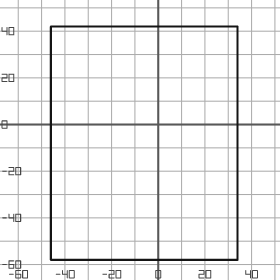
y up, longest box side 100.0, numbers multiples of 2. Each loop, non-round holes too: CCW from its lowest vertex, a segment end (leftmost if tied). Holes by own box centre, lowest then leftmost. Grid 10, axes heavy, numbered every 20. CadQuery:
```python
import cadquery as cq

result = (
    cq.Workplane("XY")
    .moveTo(-46.0, -58.0)
    .lineTo(34.0, -58.0)
    .lineTo(34.0, 42.0)
    .lineTo(-46.0, 42.0)
    .close()
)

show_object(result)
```